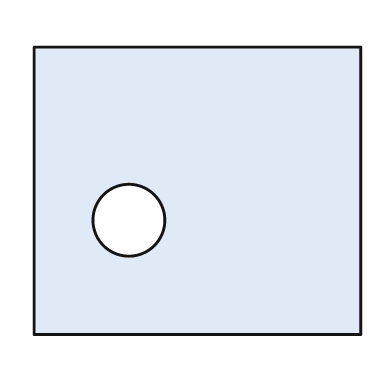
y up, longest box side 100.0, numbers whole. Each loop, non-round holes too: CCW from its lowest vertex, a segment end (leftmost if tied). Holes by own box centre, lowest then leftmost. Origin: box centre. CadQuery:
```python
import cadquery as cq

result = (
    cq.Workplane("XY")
    .moveTo(-50.0, -44.0)
    .lineTo(50.0, -44.0)
    .lineTo(50.0, 44.0)
    .lineTo(-50.0, 44.0)
    .close()
    .moveTo(-21.0, -9.0)
    .circle(11.0)
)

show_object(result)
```